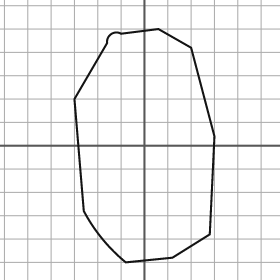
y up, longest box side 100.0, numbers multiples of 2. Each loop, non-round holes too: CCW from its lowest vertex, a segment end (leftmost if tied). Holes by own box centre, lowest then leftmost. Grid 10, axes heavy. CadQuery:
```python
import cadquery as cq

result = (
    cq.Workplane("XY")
    .moveTo(-8.0, -50.0)
    .lineTo(12.0, -48.0)
    .lineTo(28.0, -38.0)
    .lineTo(30.0, 4.0)
    .lineTo(20.0, 42.0)
    .lineTo(6.0, 50.0)
    .lineTo(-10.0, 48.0)
    .threePointArc((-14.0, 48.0), (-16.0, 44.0))
    .lineTo(-30.0, 20.0)
    .lineTo(-26.0, -28.0)
    .threePointArc((-18.0, -40.0), (-8.0, -50.0))
    .close()
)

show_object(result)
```